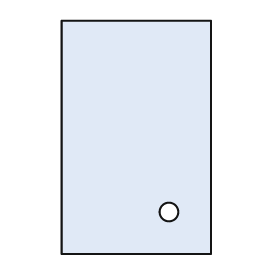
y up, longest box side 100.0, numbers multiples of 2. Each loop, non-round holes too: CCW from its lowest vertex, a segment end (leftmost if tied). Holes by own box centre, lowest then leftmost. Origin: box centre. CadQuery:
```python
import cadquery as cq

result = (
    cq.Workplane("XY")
    .moveTo(-32.0, -50.0)
    .lineTo(32.0, -50.0)
    .lineTo(32.0, 50.0)
    .lineTo(-32.0, 50.0)
    .close()
    .moveTo(14.0, -32.0)
    .circle(4.0)
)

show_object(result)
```